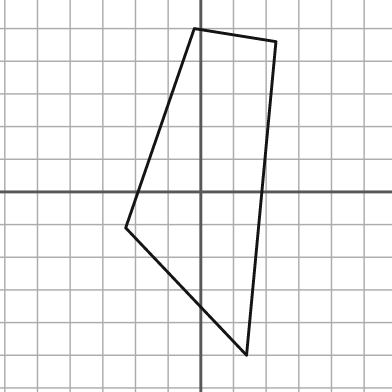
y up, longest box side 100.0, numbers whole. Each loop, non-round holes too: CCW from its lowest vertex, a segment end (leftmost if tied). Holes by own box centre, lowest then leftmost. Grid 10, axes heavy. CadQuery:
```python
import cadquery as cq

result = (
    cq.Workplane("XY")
    .moveTo(14.0, -50.0)
    .lineTo(23.0, 46.0)
    .lineTo(-2.0, 50.0)
    .lineTo(-23.0, -11.0)
    .close()
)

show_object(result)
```